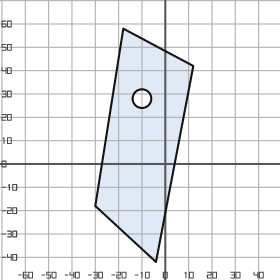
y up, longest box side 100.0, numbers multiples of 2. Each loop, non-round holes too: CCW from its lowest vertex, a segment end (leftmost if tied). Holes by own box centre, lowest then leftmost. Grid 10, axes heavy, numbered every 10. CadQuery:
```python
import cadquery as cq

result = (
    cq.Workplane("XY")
    .moveTo(-4.0, -42.0)
    .lineTo(12.0, 42.0)
    .lineTo(-18.0, 58.0)
    .lineTo(-30.0, -18.0)
    .close()
    .moveTo(-10.0, 28.0)
    .circle(4.0)
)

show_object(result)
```